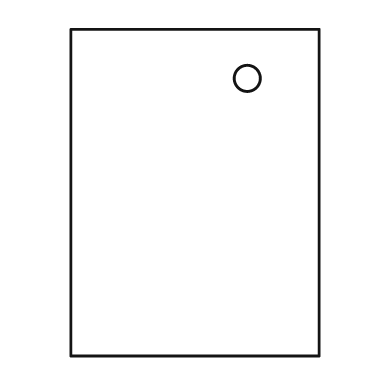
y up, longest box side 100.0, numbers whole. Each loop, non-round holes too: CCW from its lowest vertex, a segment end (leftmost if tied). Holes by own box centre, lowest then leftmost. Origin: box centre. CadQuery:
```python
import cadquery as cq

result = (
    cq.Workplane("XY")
    .moveTo(-38.0, -50.0)
    .lineTo(38.0, -50.0)
    .lineTo(38.0, 50.0)
    .lineTo(-38.0, 50.0)
    .close()
    .moveTo(16.0, 35.0)
    .circle(4.0)
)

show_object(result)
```